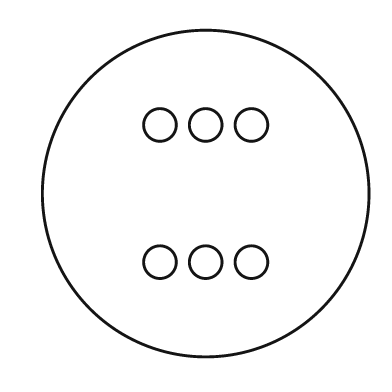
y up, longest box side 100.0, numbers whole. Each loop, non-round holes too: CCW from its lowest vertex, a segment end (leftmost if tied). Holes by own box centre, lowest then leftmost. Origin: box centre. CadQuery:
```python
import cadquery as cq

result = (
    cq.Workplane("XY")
    .moveTo(0.0, 0.0)
    .circle(50.0)
    .moveTo(-14.0, -21.0)
    .circle(5.0)
    .moveTo(0.0, -21.0)
    .circle(5.0)
    .moveTo(14.0, -21.0)
    .circle(5.0)
    .moveTo(-14.0, 21.0)
    .circle(5.0)
    .moveTo(0.0, 21.0)
    .circle(5.0)
    .moveTo(14.0, 21.0)
    .circle(5.0)
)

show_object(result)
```